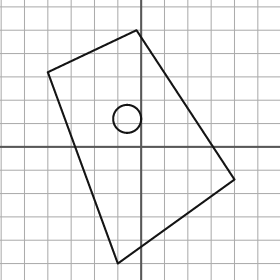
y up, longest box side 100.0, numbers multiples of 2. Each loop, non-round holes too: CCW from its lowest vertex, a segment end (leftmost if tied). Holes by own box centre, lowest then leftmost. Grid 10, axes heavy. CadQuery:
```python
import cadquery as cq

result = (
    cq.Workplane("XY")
    .moveTo(-10.0, -50.0)
    .lineTo(40.0, -14.0)
    .lineTo(-2.0, 50.0)
    .lineTo(-40.0, 32.0)
    .close()
    .moveTo(-6.0, 12.0)
    .circle(6.0)
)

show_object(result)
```